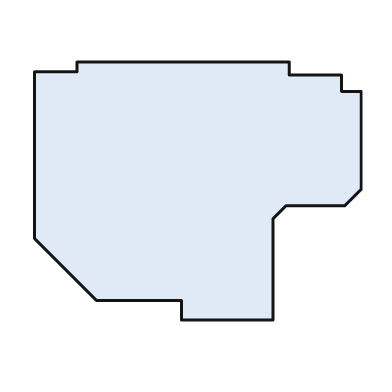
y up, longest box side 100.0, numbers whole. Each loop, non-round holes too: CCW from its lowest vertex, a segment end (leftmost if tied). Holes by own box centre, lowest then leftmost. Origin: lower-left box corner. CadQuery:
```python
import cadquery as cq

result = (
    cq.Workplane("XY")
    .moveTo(45.0, 0.0)
    .lineTo(73.0, 0.0)
    .lineTo(73.0, 31.0)
    .lineTo(77.0, 35.0)
    .lineTo(95.0, 35.0)
    .lineTo(100.0, 40.0)
    .lineTo(100.0, 70.0)
    .lineTo(94.0, 70.0)
    .lineTo(94.0, 75.0)
    .lineTo(78.0, 75.0)
    .lineTo(78.0, 79.0)
    .lineTo(13.0, 79.0)
    .lineTo(13.0, 76.0)
    .lineTo(0.0, 76.0)
    .lineTo(0.0, 25.0)
    .lineTo(19.0, 6.0)
    .lineTo(45.0, 6.0)
    .close()
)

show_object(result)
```